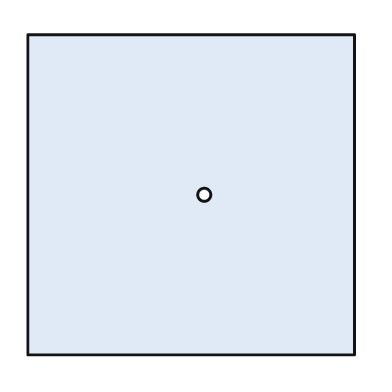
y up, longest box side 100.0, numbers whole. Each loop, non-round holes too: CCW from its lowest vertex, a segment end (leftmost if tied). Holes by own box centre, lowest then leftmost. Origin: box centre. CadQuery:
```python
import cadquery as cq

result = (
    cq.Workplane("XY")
    .moveTo(-50.0, -49.0)
    .lineTo(50.0, -49.0)
    .lineTo(50.0, 49.0)
    .lineTo(-50.0, 49.0)
    .close()
    .moveTo(4.0, 0.0)
    .circle(2.0)
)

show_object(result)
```